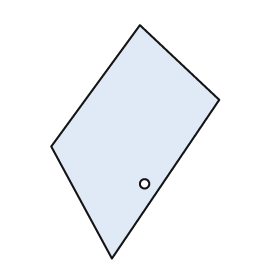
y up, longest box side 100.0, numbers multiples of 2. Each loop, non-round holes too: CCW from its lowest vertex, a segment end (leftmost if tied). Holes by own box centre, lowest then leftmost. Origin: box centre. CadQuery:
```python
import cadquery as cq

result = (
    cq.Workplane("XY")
    .moveTo(-10.0, -50.0)
    .lineTo(36.0, 18.0)
    .lineTo(2.0, 50.0)
    .lineTo(-36.0, -2.0)
    .close()
    .moveTo(4.0, -18.0)
    .circle(2.0)
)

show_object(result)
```